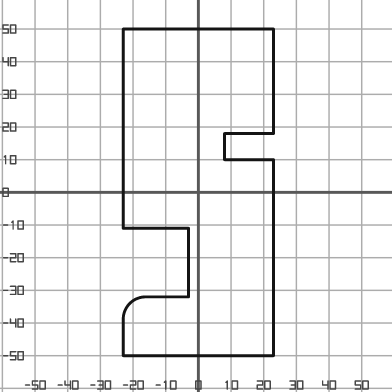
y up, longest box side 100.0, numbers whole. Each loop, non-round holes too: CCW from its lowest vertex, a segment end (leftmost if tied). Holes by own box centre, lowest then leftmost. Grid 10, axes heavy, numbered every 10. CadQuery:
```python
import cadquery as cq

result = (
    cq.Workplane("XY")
    .moveTo(-23.0, -50.0)
    .lineTo(23.0, -50.0)
    .lineTo(23.0, 10.0)
    .lineTo(8.0, 10.0)
    .lineTo(8.0, 18.0)
    .lineTo(23.0, 18.0)
    .lineTo(23.0, 50.0)
    .lineTo(-23.0, 50.0)
    .lineTo(-23.0, -11.0)
    .lineTo(-3.0, -11.0)
    .lineTo(-3.0, -32.0)
    .lineTo(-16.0, -32.0)
    .threePointArc((-21.0, -34.0), (-23.0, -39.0))
    .close()
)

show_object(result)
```